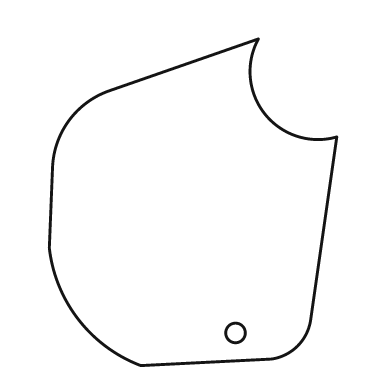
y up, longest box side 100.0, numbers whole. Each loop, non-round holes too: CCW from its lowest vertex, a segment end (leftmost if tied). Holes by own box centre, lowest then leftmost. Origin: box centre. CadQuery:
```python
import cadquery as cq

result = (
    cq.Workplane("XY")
    .moveTo(-16.0, -50.0)
    .lineTo(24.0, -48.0)
    .threePointArc((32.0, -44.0), (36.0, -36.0))
    .lineTo(44.0, 20.0)
    .threePointArc((22.0, 27.0), (20.0, 50.0))
    .lineTo(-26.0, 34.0)
    .threePointArc((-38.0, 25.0), (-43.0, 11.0))
    .lineTo(-44.0, -14.0)
    .threePointArc((-35.0, -36.0), (-16.0, -50.0))
    .close()
    .moveTo(13.0, -40.0)
    .circle(3.0)
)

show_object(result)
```